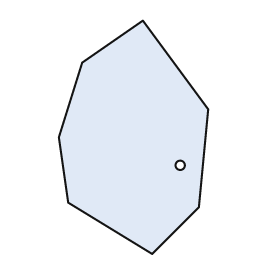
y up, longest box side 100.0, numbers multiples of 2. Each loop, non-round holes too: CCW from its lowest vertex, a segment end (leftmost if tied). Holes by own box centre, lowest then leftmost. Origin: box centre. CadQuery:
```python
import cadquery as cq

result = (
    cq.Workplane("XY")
    .moveTo(8.0, -50.0)
    .lineTo(28.0, -30.0)
    .lineTo(32.0, 12.0)
    .lineTo(4.0, 50.0)
    .lineTo(-22.0, 32.0)
    .lineTo(-32.0, 0.0)
    .lineTo(-28.0, -28.0)
    .close()
    .moveTo(20.0, -12.0)
    .circle(2.0)
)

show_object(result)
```